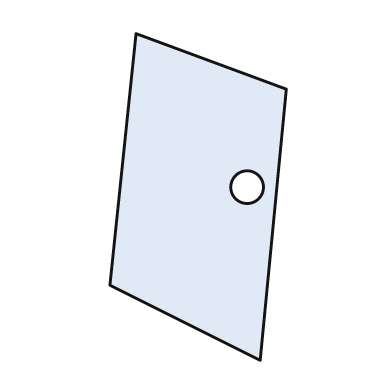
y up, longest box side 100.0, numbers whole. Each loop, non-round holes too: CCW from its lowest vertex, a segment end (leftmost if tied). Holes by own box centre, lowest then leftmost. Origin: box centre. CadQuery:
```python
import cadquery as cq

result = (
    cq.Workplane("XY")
    .moveTo(19.0, -50.0)
    .lineTo(27.0, 33.0)
    .lineTo(-19.0, 50.0)
    .lineTo(-27.0, -27.0)
    .close()
    .moveTo(15.0, 3.0)
    .circle(5.0)
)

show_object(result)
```